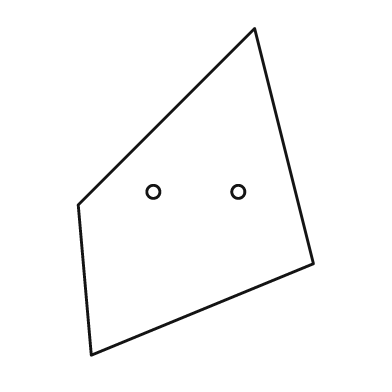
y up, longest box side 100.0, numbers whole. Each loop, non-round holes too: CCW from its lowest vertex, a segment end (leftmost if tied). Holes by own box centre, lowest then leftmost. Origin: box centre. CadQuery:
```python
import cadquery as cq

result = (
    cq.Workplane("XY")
    .moveTo(-32.0, -50.0)
    .lineTo(36.0, -22.0)
    .lineTo(18.0, 50.0)
    .lineTo(-36.0, -4.0)
    .close()
    .moveTo(-13.0, 0.0)
    .circle(2.0)
    .moveTo(13.0, 0.0)
    .circle(2.0)
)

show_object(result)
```